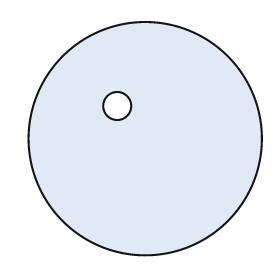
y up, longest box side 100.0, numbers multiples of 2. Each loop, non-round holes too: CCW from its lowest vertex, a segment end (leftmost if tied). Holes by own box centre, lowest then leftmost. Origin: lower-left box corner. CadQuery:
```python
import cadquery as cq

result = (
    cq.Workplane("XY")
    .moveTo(50.0, 50.0)
    .circle(50.0)
    .moveTo(38.0, 64.0)
    .circle(6.0)
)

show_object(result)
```